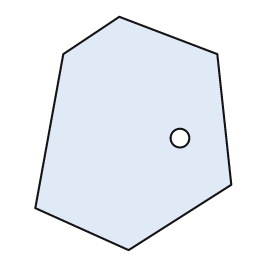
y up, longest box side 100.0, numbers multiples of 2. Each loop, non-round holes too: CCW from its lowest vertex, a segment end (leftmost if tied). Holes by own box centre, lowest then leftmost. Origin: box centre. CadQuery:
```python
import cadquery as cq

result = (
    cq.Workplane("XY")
    .moveTo(-2.0, -50.0)
    .lineTo(42.0, -22.0)
    .lineTo(36.0, 34.0)
    .lineTo(-6.0, 50.0)
    .lineTo(-30.0, 34.0)
    .lineTo(-42.0, -32.0)
    .close()
    .moveTo(20.0, -2.0)
    .circle(4.0)
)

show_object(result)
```